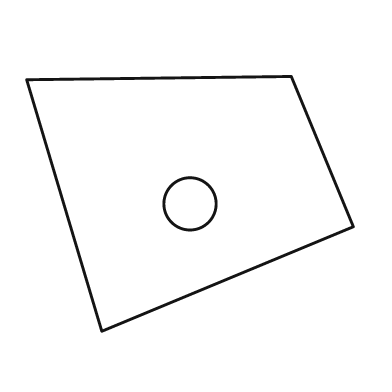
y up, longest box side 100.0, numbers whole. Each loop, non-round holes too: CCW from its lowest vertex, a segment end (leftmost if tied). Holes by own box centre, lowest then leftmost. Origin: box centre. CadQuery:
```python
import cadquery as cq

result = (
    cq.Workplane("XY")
    .moveTo(-27.0, -39.0)
    .lineTo(50.0, -7.0)
    .lineTo(31.0, 39.0)
    .lineTo(-50.0, 38.0)
    .close()
    .moveTo(0.0, 0.0)
    .circle(8.0)
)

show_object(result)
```